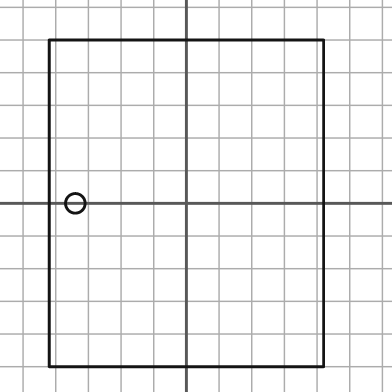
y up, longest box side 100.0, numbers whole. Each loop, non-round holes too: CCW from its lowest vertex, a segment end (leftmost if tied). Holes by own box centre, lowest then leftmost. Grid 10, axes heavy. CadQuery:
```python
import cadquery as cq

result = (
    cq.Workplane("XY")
    .moveTo(-42.0, -50.0)
    .lineTo(42.0, -50.0)
    .lineTo(42.0, 50.0)
    .lineTo(-42.0, 50.0)
    .close()
    .moveTo(-34.0, 0.0)
    .circle(3.0)
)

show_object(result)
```